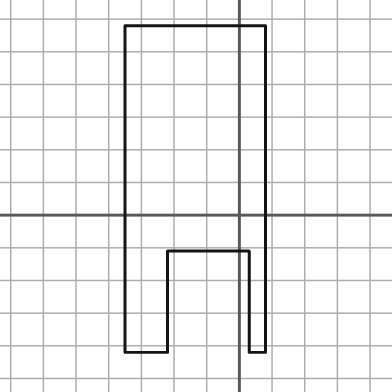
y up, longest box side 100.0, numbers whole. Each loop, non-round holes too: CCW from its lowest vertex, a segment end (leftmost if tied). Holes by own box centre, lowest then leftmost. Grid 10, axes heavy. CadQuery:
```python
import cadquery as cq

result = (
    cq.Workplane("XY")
    .moveTo(-35.0, -42.0)
    .lineTo(-22.0, -42.0)
    .lineTo(-22.0, -11.0)
    .lineTo(3.0, -11.0)
    .lineTo(3.0, -42.0)
    .lineTo(8.0, -42.0)
    .lineTo(8.0, 58.0)
    .lineTo(-35.0, 58.0)
    .close()
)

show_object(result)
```